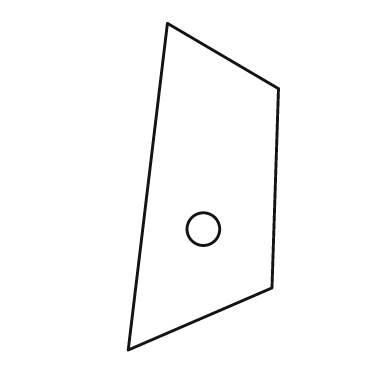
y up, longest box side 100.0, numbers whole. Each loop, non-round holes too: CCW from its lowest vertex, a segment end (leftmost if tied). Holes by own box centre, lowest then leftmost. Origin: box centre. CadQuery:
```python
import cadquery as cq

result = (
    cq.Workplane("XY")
    .moveTo(-23.0, -50.0)
    .lineTo(21.0, -31.0)
    .lineTo(23.0, 30.0)
    .lineTo(-11.0, 50.0)
    .close()
    .moveTo(0.0, -13.0)
    .circle(5.0)
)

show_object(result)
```